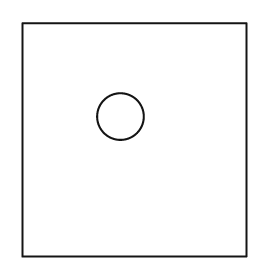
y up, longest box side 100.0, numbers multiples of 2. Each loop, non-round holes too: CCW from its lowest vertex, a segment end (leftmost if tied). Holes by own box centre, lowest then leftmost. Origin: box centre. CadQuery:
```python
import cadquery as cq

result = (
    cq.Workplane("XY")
    .moveTo(-48.0, -50.0)
    .lineTo(48.0, -50.0)
    .lineTo(48.0, 50.0)
    .lineTo(-48.0, 50.0)
    .close()
    .moveTo(-6.0, 10.0)
    .circle(10.0)
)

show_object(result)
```